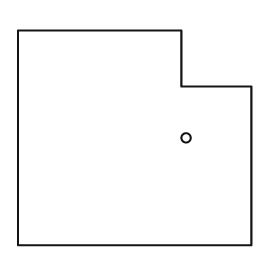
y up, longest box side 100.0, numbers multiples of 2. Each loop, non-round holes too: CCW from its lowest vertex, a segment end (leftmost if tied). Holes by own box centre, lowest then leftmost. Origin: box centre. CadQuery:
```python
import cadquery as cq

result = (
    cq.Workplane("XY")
    .moveTo(-50.0, -46.0)
    .lineTo(50.0, -46.0)
    .lineTo(50.0, 22.0)
    .lineTo(20.0, 22.0)
    .lineTo(20.0, 46.0)
    .lineTo(-50.0, 46.0)
    .close()
    .moveTo(22.0, 0.0)
    .circle(2.0)
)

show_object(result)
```